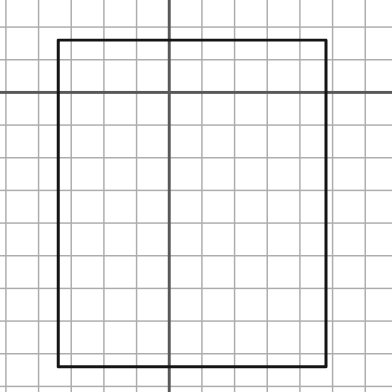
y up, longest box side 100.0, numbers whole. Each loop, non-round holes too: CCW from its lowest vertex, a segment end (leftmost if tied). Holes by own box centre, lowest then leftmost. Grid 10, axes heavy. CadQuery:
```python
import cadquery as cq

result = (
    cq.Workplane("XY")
    .moveTo(-34.0, -84.0)
    .lineTo(48.0, -84.0)
    .lineTo(48.0, 16.0)
    .lineTo(-34.0, 16.0)
    .close()
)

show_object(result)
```